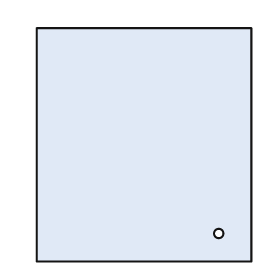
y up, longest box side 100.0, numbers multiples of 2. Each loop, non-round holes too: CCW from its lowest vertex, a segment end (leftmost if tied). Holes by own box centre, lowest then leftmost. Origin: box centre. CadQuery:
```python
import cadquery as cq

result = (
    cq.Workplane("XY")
    .moveTo(-46.0, -50.0)
    .lineTo(46.0, -50.0)
    .lineTo(46.0, 50.0)
    .lineTo(-46.0, 50.0)
    .close()
    .moveTo(32.0, -38.0)
    .circle(2.0)
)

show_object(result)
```